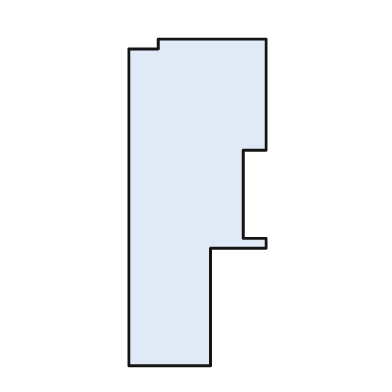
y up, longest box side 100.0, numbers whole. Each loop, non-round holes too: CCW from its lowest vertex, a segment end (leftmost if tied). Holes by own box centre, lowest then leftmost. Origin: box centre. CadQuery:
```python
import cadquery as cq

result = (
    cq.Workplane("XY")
    .moveTo(-21.0, -50.0)
    .lineTo(4.0, -50.0)
    .lineTo(4.0, -14.0)
    .lineTo(21.0, -14.0)
    .lineTo(21.0, -11.0)
    .lineTo(14.0, -11.0)
    .lineTo(14.0, 16.0)
    .lineTo(21.0, 16.0)
    .lineTo(21.0, 50.0)
    .lineTo(-12.0, 50.0)
    .lineTo(-12.0, 47.0)
    .lineTo(-21.0, 47.0)
    .close()
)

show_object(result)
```